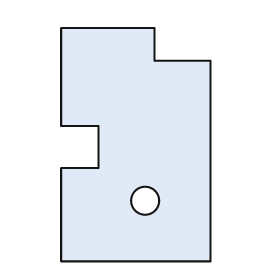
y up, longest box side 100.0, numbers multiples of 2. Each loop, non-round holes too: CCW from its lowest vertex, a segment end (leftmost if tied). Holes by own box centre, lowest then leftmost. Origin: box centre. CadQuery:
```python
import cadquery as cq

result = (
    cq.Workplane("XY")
    .moveTo(-32.0, -50.0)
    .lineTo(32.0, -50.0)
    .lineTo(32.0, 36.0)
    .lineTo(8.0, 36.0)
    .lineTo(8.0, 50.0)
    .lineTo(-32.0, 50.0)
    .lineTo(-32.0, 8.0)
    .lineTo(-16.0, 8.0)
    .lineTo(-16.0, -10.0)
    .lineTo(-32.0, -10.0)
    .close()
    .moveTo(4.0, -24.0)
    .circle(6.0)
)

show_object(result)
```